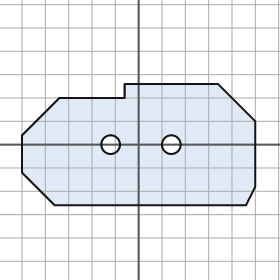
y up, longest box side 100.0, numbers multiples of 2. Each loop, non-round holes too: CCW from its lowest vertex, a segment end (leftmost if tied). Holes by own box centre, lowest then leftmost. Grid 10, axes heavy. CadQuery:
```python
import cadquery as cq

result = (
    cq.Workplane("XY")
    .moveTo(-36.0, -26.0)
    .lineTo(46.0, -26.0)
    .lineTo(50.0, -18.0)
    .lineTo(50.0, 10.0)
    .lineTo(34.0, 26.0)
    .lineTo(-6.0, 26.0)
    .lineTo(-6.0, 20.0)
    .lineTo(-34.0, 20.0)
    .lineTo(-50.0, 4.0)
    .lineTo(-50.0, -12.0)
    .close()
    .moveTo(-12.0, 0.0)
    .circle(4.0)
    .moveTo(14.0, 0.0)
    .circle(4.0)
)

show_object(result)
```